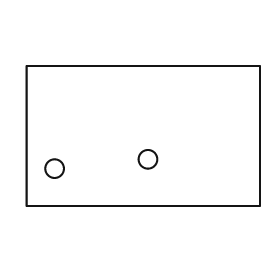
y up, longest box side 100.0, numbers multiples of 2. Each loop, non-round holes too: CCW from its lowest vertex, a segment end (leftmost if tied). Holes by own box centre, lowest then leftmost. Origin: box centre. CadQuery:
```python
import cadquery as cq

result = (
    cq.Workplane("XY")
    .moveTo(-50.0, -30.0)
    .lineTo(50.0, -30.0)
    .lineTo(50.0, 30.0)
    .lineTo(-50.0, 30.0)
    .close()
    .moveTo(-38.0, -14.0)
    .circle(4.0)
    .moveTo(2.0, -10.0)
    .circle(4.0)
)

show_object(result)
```